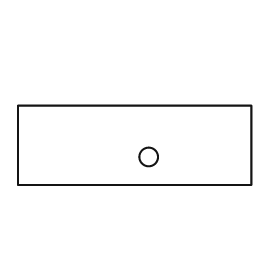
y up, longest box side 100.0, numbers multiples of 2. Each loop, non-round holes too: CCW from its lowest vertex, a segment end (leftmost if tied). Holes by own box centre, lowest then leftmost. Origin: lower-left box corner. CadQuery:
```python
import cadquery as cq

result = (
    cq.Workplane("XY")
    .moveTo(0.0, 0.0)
    .lineTo(100.0, 0.0)
    .lineTo(100.0, 34.0)
    .lineTo(0.0, 34.0)
    .close()
    .moveTo(56.0, 12.0)
    .circle(4.0)
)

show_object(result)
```